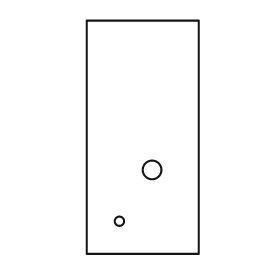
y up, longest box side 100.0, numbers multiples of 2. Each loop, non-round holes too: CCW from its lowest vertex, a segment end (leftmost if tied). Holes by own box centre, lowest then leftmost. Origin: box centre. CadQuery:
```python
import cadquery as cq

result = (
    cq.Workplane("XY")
    .moveTo(-24.0, -50.0)
    .lineTo(24.0, -50.0)
    .lineTo(24.0, 50.0)
    .lineTo(-24.0, 50.0)
    .close()
    .moveTo(-10.0, -36.0)
    .circle(2.0)
    .moveTo(4.0, -14.0)
    .circle(4.0)
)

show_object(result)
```